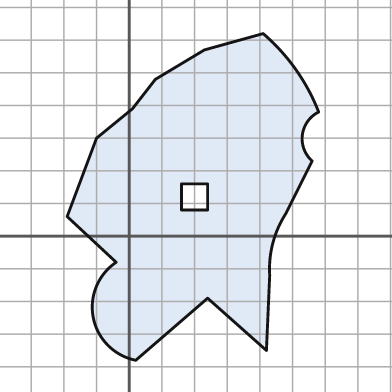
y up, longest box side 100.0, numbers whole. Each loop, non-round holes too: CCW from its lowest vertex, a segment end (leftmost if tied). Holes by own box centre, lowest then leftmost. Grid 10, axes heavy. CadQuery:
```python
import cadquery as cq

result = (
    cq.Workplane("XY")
    .moveTo(2.0, -38.0)
    .lineTo(24.0, -19.0)
    .lineTo(42.0, -35.0)
    .lineTo(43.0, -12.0)
    .threePointArc((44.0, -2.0), (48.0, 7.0))
    .lineTo(56.0, 23.0)
    .threePointArc((53.0, 31.0), (58.0, 38.0))
    .threePointArc((51.0, 51.0), (41.0, 62.0))
    .lineTo(23.0, 57.0)
    .lineTo(8.0, 48.0)
    .lineTo(1.0, 39.0)
    .lineTo(-10.0, 30.0)
    .lineTo(-19.0, 6.0)
    .lineTo(-4.0, -8.0)
    .threePointArc((-11.0, -25.0), (2.0, -38.0))
    .close()
    .moveTo(16.0, 8.0)
    .lineTo(24.0, 8.0)
    .lineTo(24.0, 16.0)
    .lineTo(16.0, 16.0)
    .close()
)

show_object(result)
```